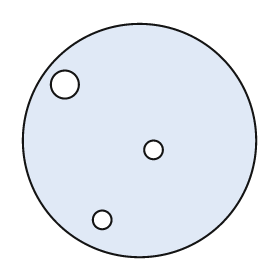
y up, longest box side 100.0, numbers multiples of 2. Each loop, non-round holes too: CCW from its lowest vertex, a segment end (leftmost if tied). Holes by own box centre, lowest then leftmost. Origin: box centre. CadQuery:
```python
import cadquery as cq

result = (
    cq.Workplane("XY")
    .moveTo(0.0, 0.0)
    .circle(50.0)
    .moveTo(-16.0, -34.0)
    .circle(4.0)
    .moveTo(6.0, -4.0)
    .circle(4.0)
    .moveTo(-32.0, 24.0)
    .circle(6.0)
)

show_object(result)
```